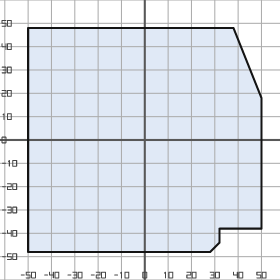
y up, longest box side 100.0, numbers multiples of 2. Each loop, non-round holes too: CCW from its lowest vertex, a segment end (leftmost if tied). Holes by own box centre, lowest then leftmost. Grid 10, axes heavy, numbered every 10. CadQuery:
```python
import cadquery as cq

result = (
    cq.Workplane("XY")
    .moveTo(-50.0, -48.0)
    .lineTo(28.0, -48.0)
    .lineTo(32.0, -44.0)
    .lineTo(32.0, -38.0)
    .lineTo(50.0, -38.0)
    .lineTo(50.0, 18.0)
    .lineTo(38.0, 48.0)
    .lineTo(-50.0, 48.0)
    .close()
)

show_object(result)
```